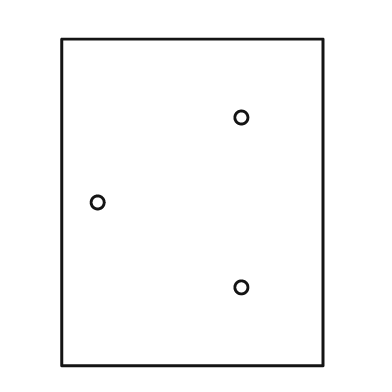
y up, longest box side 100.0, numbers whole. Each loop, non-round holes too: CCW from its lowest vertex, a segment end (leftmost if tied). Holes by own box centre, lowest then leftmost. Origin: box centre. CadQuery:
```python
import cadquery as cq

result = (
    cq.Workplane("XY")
    .moveTo(-40.0, -50.0)
    .lineTo(40.0, -50.0)
    .lineTo(40.0, 50.0)
    .lineTo(-40.0, 50.0)
    .close()
    .moveTo(15.0, -26.0)
    .circle(2.0)
    .moveTo(-29.0, 0.0)
    .circle(2.0)
    .moveTo(15.0, 26.0)
    .circle(2.0)
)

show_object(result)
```